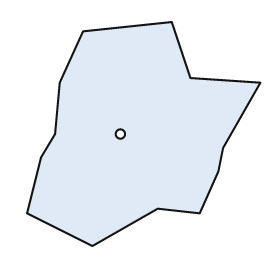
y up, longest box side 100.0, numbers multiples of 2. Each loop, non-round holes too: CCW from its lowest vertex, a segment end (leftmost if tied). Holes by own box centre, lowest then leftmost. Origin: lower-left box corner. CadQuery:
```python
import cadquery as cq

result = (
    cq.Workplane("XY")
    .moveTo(28.0, 0.0)
    .lineTo(56.0, 16.0)
    .lineTo(74.0, 14.0)
    .lineTo(82.0, 32.0)
    .lineTo(84.0, 42.0)
    .lineTo(100.0, 70.0)
    .lineTo(70.0, 72.0)
    .lineTo(62.0, 96.0)
    .lineTo(24.0, 92.0)
    .lineTo(14.0, 70.0)
    .lineTo(12.0, 48.0)
    .lineTo(6.0, 38.0)
    .lineTo(0.0, 14.0)
    .close()
    .moveTo(40.0, 48.0)
    .circle(2.0)
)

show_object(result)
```